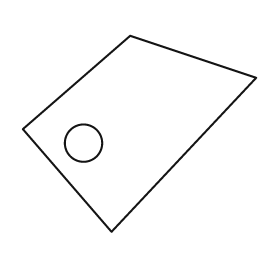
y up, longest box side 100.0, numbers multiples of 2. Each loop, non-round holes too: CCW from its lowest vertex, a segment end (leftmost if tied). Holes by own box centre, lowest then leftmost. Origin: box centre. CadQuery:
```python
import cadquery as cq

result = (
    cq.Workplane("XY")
    .moveTo(-12.0, -42.0)
    .lineTo(50.0, 24.0)
    .lineTo(-4.0, 42.0)
    .lineTo(-50.0, 2.0)
    .close()
    .moveTo(-24.0, -4.0)
    .circle(8.0)
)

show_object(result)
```